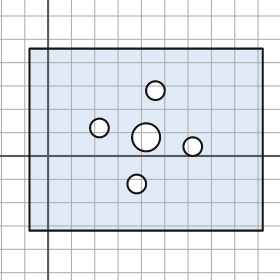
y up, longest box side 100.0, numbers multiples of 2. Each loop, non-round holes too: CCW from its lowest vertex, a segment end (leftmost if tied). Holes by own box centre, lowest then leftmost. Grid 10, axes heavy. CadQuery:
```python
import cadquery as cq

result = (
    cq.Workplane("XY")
    .moveTo(-8.0, -32.0)
    .lineTo(92.0, -32.0)
    .lineTo(92.0, 46.0)
    .lineTo(-8.0, 46.0)
    .close()
    .moveTo(38.0, -12.0)
    .circle(4.0)
    .moveTo(62.0, 4.0)
    .circle(4.0)
    .moveTo(42.0, 8.0)
    .circle(6.0)
    .moveTo(22.0, 12.0)
    .circle(4.0)
    .moveTo(46.0, 28.0)
    .circle(4.0)
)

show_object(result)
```